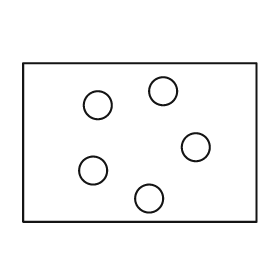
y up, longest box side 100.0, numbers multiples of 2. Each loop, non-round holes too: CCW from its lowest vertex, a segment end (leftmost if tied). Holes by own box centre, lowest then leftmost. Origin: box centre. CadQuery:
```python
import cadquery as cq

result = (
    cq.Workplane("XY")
    .moveTo(-50.0, -34.0)
    .lineTo(50.0, -34.0)
    .lineTo(50.0, 34.0)
    .lineTo(-50.0, 34.0)
    .close()
    .moveTo(4.0, -24.0)
    .circle(6.0)
    .moveTo(-20.0, -12.0)
    .circle(6.0)
    .moveTo(24.0, -2.0)
    .circle(6.0)
    .moveTo(-18.0, 16.0)
    .circle(6.0)
    .moveTo(10.0, 22.0)
    .circle(6.0)
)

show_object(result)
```